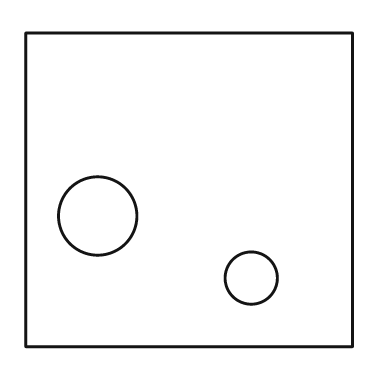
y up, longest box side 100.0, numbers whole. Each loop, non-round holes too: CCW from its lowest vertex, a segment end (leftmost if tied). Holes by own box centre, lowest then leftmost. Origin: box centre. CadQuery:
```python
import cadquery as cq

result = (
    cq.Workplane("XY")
    .moveTo(-50.0, -48.0)
    .lineTo(50.0, -48.0)
    .lineTo(50.0, 48.0)
    .lineTo(-50.0, 48.0)
    .close()
    .moveTo(19.0, -27.0)
    .circle(8.0)
    .moveTo(-28.0, -8.0)
    .circle(12.0)
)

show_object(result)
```